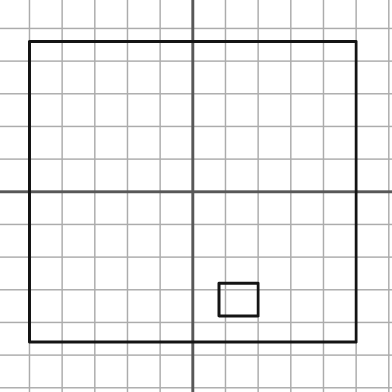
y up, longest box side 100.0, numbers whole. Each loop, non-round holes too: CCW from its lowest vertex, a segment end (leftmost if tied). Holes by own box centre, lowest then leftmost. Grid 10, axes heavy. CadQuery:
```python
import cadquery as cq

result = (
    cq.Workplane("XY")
    .moveTo(-50.0, -46.0)
    .lineTo(50.0, -46.0)
    .lineTo(50.0, 46.0)
    .lineTo(-50.0, 46.0)
    .close()
    .moveTo(8.0, -38.0)
    .lineTo(20.0, -38.0)
    .lineTo(20.0, -28.0)
    .lineTo(8.0, -28.0)
    .close()
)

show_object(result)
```